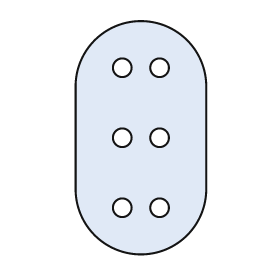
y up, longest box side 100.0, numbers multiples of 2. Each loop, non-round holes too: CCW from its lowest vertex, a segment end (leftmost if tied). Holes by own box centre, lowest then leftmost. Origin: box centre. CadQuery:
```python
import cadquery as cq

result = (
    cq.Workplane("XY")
    .moveTo(-28.0, -22.0)
    .threePointArc((0.0, -50.0), (28.0, -22.0))
    .lineTo(28.0, 22.0)
    .threePointArc((0.0, 50.0), (-28.0, 22.0))
    .close()
    .moveTo(-8.0, -30.0)
    .circle(4.0)
    .moveTo(8.0, -30.0)
    .circle(4.0)
    .moveTo(-8.0, 0.0)
    .circle(4.0)
    .moveTo(8.0, 0.0)
    .circle(4.0)
    .moveTo(-8.0, 30.0)
    .circle(4.0)
    .moveTo(8.0, 30.0)
    .circle(4.0)
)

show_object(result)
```